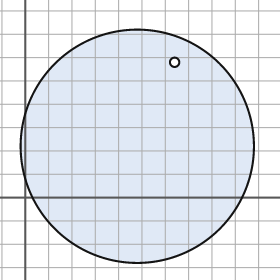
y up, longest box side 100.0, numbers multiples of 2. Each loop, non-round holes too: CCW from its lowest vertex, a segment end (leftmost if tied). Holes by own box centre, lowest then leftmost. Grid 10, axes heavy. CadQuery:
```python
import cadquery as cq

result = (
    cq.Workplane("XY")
    .moveTo(48.0, 22.0)
    .circle(50.0)
    .moveTo(64.0, 58.0)
    .circle(2.0)
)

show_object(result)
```